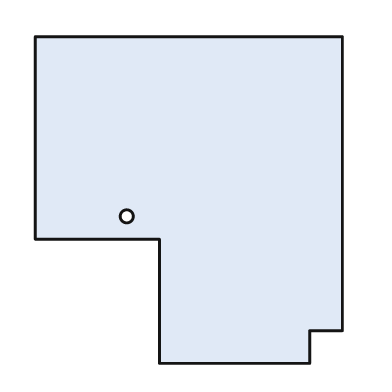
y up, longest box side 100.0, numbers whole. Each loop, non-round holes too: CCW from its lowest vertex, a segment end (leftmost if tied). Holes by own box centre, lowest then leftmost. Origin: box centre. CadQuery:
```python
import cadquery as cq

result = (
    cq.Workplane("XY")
    .moveTo(-9.0, -50.0)
    .lineTo(37.0, -50.0)
    .lineTo(37.0, -40.0)
    .lineTo(47.0, -40.0)
    .lineTo(47.0, 50.0)
    .lineTo(-47.0, 50.0)
    .lineTo(-47.0, -12.0)
    .lineTo(-9.0, -12.0)
    .close()
    .moveTo(-19.0, -5.0)
    .circle(2.0)
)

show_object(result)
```